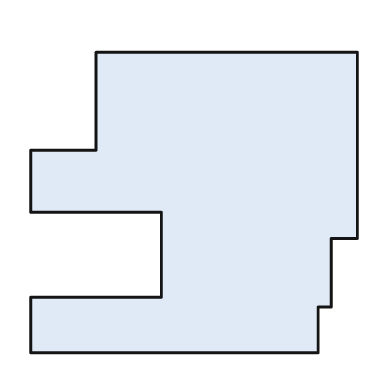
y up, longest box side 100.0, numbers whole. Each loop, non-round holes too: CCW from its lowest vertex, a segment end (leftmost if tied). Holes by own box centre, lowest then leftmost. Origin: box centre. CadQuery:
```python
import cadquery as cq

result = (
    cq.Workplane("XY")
    .moveTo(-50.0, -46.0)
    .lineTo(38.0, -46.0)
    .lineTo(38.0, -32.0)
    .lineTo(42.0, -32.0)
    .lineTo(42.0, -11.0)
    .lineTo(50.0, -11.0)
    .lineTo(50.0, 46.0)
    .lineTo(-30.0, 46.0)
    .lineTo(-30.0, 16.0)
    .lineTo(-50.0, 16.0)
    .lineTo(-50.0, -3.0)
    .lineTo(-10.0, -3.0)
    .lineTo(-10.0, -29.0)
    .lineTo(-50.0, -29.0)
    .close()
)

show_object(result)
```